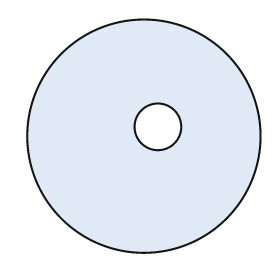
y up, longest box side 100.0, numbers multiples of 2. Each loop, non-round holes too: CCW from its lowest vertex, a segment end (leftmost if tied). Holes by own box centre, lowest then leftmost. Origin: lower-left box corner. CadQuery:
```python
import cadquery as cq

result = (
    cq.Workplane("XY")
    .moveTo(50.0, 50.0)
    .circle(50.0)
    .moveTo(56.0, 54.0)
    .circle(10.0)
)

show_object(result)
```